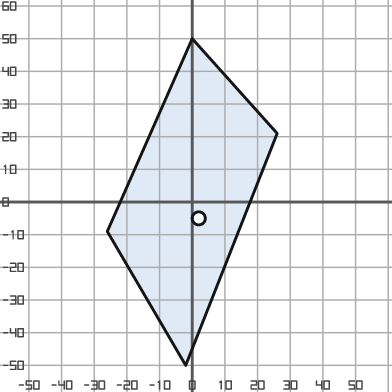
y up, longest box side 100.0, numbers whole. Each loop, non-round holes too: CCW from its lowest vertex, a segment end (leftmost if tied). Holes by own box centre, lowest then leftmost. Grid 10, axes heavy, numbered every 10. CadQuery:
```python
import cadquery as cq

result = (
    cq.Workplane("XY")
    .moveTo(-2.0, -50.0)
    .lineTo(26.0, 21.0)
    .lineTo(0.0, 50.0)
    .lineTo(-26.0, -9.0)
    .close()
    .moveTo(2.0, -5.0)
    .circle(2.0)
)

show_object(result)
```